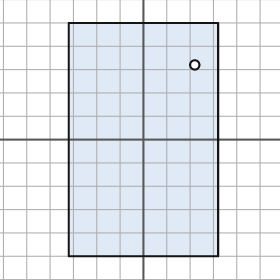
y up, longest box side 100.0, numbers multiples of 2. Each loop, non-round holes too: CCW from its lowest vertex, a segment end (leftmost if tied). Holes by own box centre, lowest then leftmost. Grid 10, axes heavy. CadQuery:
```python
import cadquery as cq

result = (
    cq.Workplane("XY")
    .moveTo(-32.0, -50.0)
    .lineTo(32.0, -50.0)
    .lineTo(32.0, 50.0)
    .lineTo(-32.0, 50.0)
    .close()
    .moveTo(22.0, 32.0)
    .circle(2.0)
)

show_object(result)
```